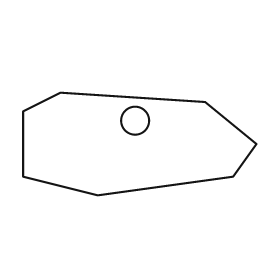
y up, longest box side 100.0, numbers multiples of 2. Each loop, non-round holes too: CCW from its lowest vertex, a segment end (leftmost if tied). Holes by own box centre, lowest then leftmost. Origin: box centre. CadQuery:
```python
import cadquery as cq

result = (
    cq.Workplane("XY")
    .moveTo(-18.0, -22.0)
    .lineTo(40.0, -14.0)
    .lineTo(50.0, 0.0)
    .lineTo(28.0, 18.0)
    .lineTo(-34.0, 22.0)
    .lineTo(-50.0, 14.0)
    .lineTo(-50.0, -14.0)
    .close()
    .moveTo(-2.0, 10.0)
    .circle(6.0)
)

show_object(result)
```